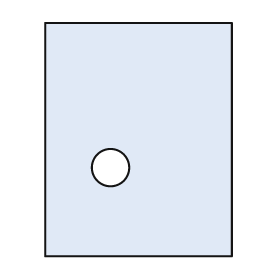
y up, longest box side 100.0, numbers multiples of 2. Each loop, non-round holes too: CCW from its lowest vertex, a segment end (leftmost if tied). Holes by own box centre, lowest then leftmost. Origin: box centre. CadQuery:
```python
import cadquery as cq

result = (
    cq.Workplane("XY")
    .moveTo(-40.0, -50.0)
    .lineTo(40.0, -50.0)
    .lineTo(40.0, 50.0)
    .lineTo(-40.0, 50.0)
    .close()
    .moveTo(-12.0, -12.0)
    .circle(8.0)
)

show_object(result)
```